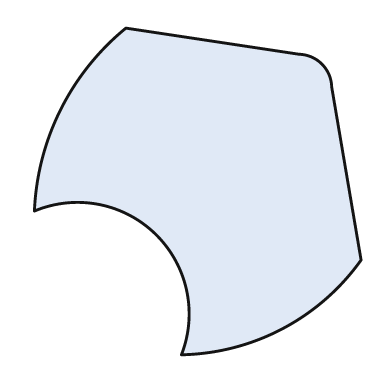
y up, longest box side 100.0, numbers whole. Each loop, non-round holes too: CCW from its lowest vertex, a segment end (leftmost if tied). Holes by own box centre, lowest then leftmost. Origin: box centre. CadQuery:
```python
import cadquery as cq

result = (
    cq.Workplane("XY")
    .moveTo(-5.0, -50.0)
    .threePointArc((26.0, -42.0), (50.0, -21.0))
    .lineTo(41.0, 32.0)
    .threePointArc((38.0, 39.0), (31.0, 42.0))
    .lineTo(-22.0, 50.0)
    .threePointArc((-42.0, 25.0), (-50.0, -6.0))
    .threePointArc((-13.0, -13.0), (-5.0, -50.0))
    .close()
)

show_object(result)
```